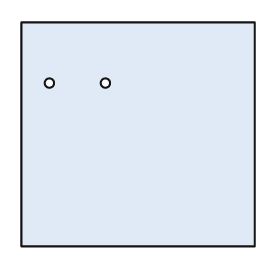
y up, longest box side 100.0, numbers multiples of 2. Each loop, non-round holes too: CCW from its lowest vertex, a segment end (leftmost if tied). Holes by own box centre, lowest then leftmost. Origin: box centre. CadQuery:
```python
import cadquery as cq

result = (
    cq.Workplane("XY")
    .moveTo(-50.0, -48.0)
    .lineTo(50.0, -48.0)
    .lineTo(50.0, 48.0)
    .lineTo(-50.0, 48.0)
    .close()
    .moveTo(-38.0, 22.0)
    .circle(2.0)
    .moveTo(-14.0, 22.0)
    .circle(2.0)
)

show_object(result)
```